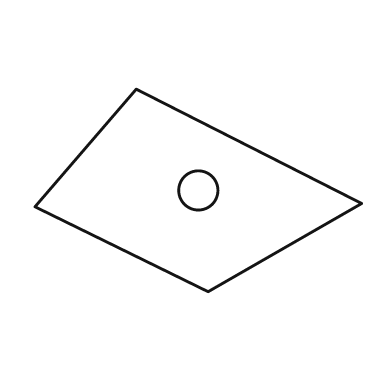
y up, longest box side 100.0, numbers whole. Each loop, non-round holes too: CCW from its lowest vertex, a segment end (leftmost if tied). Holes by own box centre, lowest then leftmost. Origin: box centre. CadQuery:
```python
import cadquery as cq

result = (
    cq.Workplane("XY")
    .moveTo(3.0, -31.0)
    .lineTo(50.0, -4.0)
    .lineTo(-19.0, 31.0)
    .lineTo(-50.0, -5.0)
    .close()
    .moveTo(0.0, 0.0)
    .circle(6.0)
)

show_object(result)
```